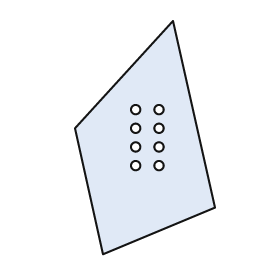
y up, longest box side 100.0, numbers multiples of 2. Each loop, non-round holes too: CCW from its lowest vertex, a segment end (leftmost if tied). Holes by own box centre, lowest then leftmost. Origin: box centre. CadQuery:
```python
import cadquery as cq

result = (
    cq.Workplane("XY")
    .moveTo(-18.0, -50.0)
    .lineTo(30.0, -30.0)
    .lineTo(12.0, 50.0)
    .lineTo(-30.0, 4.0)
    .close()
    .moveTo(-4.0, -12.0)
    .circle(2.0)
    .moveTo(6.0, -12.0)
    .circle(2.0)
    .moveTo(-4.0, -4.0)
    .circle(2.0)
    .moveTo(6.0, -4.0)
    .circle(2.0)
    .moveTo(-4.0, 4.0)
    .circle(2.0)
    .moveTo(6.0, 4.0)
    .circle(2.0)
    .moveTo(-4.0, 12.0)
    .circle(2.0)
    .moveTo(6.0, 12.0)
    .circle(2.0)
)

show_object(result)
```